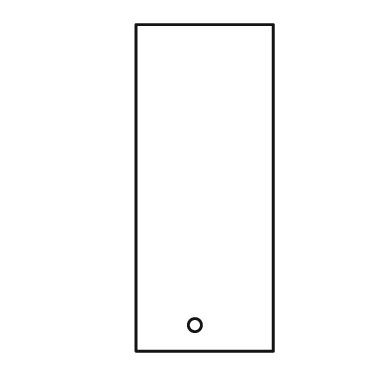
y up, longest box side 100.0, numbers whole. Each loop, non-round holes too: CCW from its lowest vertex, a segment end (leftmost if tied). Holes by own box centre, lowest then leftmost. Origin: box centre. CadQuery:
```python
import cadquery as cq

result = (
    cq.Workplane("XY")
    .moveTo(-21.0, -50.0)
    .lineTo(21.0, -50.0)
    .lineTo(21.0, 50.0)
    .lineTo(-21.0, 50.0)
    .close()
    .moveTo(-3.0, -42.0)
    .circle(2.0)
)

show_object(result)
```